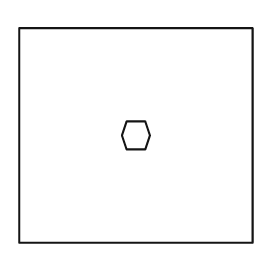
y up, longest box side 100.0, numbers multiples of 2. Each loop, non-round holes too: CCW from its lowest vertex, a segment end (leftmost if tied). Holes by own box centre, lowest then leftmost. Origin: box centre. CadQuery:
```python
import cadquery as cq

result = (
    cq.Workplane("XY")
    .moveTo(-50.0, -46.0)
    .lineTo(50.0, -46.0)
    .lineTo(50.0, 46.0)
    .lineTo(-50.0, 46.0)
    .close()
    .moveTo(-4.0, -6.0)
    .lineTo(4.0, -6.0)
    .lineTo(6.0, 0.0)
    .lineTo(4.0, 6.0)
    .lineTo(-4.0, 6.0)
    .lineTo(-6.0, 0.0)
    .close()
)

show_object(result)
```